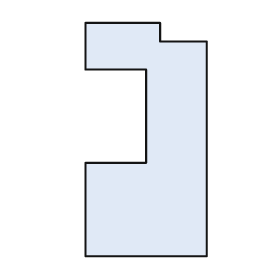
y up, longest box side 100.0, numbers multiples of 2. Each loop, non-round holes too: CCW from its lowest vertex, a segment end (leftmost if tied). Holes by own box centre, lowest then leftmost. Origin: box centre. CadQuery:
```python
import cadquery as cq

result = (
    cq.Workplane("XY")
    .moveTo(-26.0, -50.0)
    .lineTo(26.0, -50.0)
    .lineTo(26.0, 42.0)
    .lineTo(6.0, 42.0)
    .lineTo(6.0, 50.0)
    .lineTo(-26.0, 50.0)
    .lineTo(-26.0, 30.0)
    .lineTo(0.0, 30.0)
    .lineTo(0.0, -10.0)
    .lineTo(-26.0, -10.0)
    .close()
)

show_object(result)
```